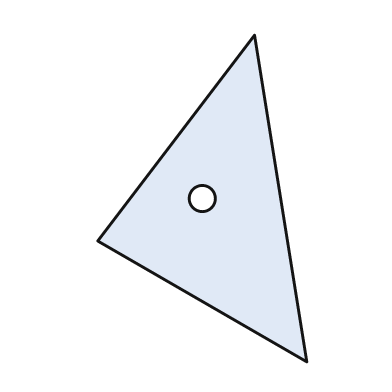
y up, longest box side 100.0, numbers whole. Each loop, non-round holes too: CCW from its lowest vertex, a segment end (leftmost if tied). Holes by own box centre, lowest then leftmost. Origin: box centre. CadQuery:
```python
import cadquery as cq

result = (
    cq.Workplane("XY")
    .moveTo(32.0, -50.0)
    .lineTo(16.0, 50.0)
    .lineTo(-32.0, -13.0)
    .close()
    .moveTo(0.0, 0.0)
    .circle(4.0)
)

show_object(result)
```